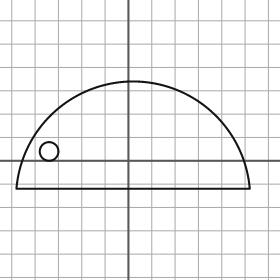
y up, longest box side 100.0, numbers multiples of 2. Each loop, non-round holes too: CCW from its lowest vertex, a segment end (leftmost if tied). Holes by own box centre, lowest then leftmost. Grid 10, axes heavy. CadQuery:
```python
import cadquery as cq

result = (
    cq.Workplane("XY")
    .moveTo(-48.0, -12.0)
    .lineTo(52.0, -12.0)
    .threePointArc((2.0, 34.0), (-48.0, -12.0))
    .close()
    .moveTo(-34.0, 4.0)
    .circle(4.0)
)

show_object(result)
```